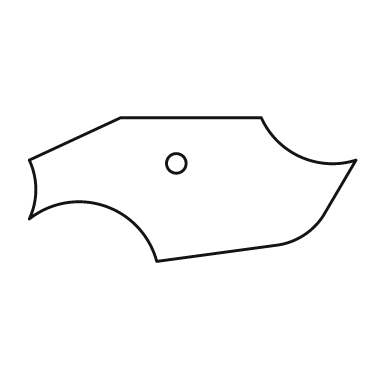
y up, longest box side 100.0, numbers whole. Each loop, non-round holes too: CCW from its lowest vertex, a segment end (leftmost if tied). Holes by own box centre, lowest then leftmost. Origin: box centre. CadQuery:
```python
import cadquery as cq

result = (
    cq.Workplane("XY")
    .moveTo(-11.0, -22.0)
    .lineTo(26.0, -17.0)
    .threePointArc((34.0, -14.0), (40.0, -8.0))
    .lineTo(50.0, 9.0)
    .threePointArc((33.0, 10.0), (21.0, 22.0))
    .lineTo(-22.0, 22.0)
    .lineTo(-50.0, 9.0)
    .threePointArc((-48.0, 0.0), (-50.0, -9.0))
    .threePointArc((-27.0, -5.0), (-11.0, -22.0))
    .close()
    .moveTo(-5.0, 8.0)
    .circle(3.0)
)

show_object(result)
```